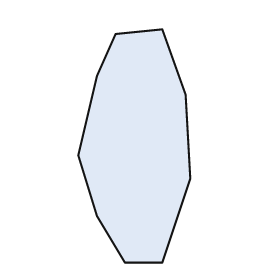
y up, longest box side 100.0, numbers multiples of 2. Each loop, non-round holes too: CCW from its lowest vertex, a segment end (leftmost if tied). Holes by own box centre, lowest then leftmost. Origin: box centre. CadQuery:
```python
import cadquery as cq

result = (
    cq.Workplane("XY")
    .moveTo(-4.0, -50.0)
    .lineTo(12.0, -50.0)
    .lineTo(24.0, -14.0)
    .lineTo(22.0, 22.0)
    .lineTo(12.0, 50.0)
    .lineTo(-8.0, 48.0)
    .lineTo(-16.0, 30.0)
    .lineTo(-24.0, -4.0)
    .lineTo(-16.0, -30.0)
    .close()
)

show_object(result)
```